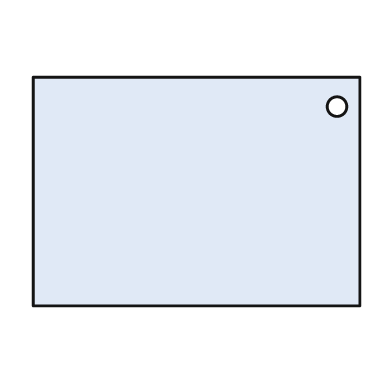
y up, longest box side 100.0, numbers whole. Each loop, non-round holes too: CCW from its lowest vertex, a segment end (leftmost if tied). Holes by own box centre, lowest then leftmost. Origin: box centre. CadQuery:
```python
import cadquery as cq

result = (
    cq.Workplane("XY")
    .moveTo(-50.0, -35.0)
    .lineTo(50.0, -35.0)
    .lineTo(50.0, 35.0)
    .lineTo(-50.0, 35.0)
    .close()
    .moveTo(43.0, 26.0)
    .circle(3.0)
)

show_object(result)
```